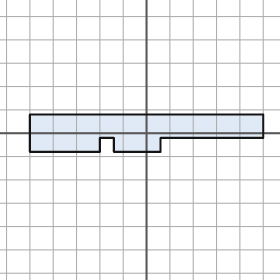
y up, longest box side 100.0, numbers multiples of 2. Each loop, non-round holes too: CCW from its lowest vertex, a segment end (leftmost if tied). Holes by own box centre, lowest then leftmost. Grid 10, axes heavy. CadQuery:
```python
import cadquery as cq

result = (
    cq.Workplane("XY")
    .moveTo(-50.0, -8.0)
    .lineTo(-20.0, -8.0)
    .lineTo(-20.0, -2.0)
    .lineTo(-14.0, -2.0)
    .lineTo(-14.0, -8.0)
    .lineTo(6.0, -8.0)
    .lineTo(6.0, -2.0)
    .lineTo(50.0, -2.0)
    .lineTo(50.0, 8.0)
    .lineTo(-50.0, 8.0)
    .close()
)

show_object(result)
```